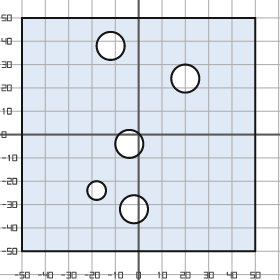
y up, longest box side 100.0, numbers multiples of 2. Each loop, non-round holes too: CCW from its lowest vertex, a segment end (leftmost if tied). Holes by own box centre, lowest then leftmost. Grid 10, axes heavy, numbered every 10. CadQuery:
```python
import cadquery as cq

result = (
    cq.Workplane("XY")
    .moveTo(-50.0, -50.0)
    .lineTo(50.0, -50.0)
    .lineTo(50.0, 50.0)
    .lineTo(-50.0, 50.0)
    .close()
    .moveTo(-2.0, -32.0)
    .circle(6.0)
    .moveTo(-18.0, -24.0)
    .circle(4.0)
    .moveTo(-4.0, -4.0)
    .circle(6.0)
    .moveTo(20.0, 24.0)
    .circle(6.0)
    .moveTo(-12.0, 38.0)
    .circle(6.0)
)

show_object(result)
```